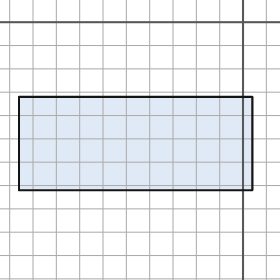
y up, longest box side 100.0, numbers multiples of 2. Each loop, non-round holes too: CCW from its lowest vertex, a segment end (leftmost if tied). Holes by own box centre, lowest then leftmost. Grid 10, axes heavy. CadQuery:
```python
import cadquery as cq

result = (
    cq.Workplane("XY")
    .moveTo(-96.0, -72.0)
    .lineTo(4.0, -72.0)
    .lineTo(4.0, -32.0)
    .lineTo(-96.0, -32.0)
    .close()
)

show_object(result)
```